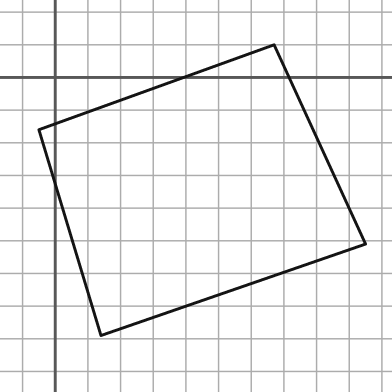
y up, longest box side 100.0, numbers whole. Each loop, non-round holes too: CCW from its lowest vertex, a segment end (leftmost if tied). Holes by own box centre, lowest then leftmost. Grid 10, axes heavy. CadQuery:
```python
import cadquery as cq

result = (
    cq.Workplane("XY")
    .moveTo(14.0, -79.0)
    .lineTo(95.0, -51.0)
    .lineTo(67.0, 10.0)
    .lineTo(-5.0, -16.0)
    .close()
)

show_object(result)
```